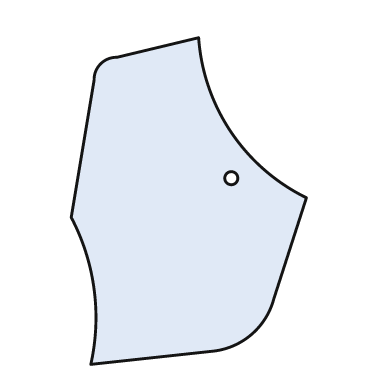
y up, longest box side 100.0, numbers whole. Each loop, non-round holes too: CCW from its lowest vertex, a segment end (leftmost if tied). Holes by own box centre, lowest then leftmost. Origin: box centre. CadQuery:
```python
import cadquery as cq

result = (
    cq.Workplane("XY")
    .moveTo(-30.0, -50.0)
    .lineTo(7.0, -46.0)
    .threePointArc((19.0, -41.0), (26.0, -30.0))
    .lineTo(36.0, 1.0)
    .threePointArc((13.0, 21.0), (3.0, 50.0))
    .lineTo(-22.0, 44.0)
    .threePointArc((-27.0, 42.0), (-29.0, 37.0))
    .lineTo(-36.0, -5.0)
    .threePointArc((-29.0, -27.0), (-30.0, -50.0))
    .close()
    .moveTo(13.0, 7.0)
    .circle(2.0)
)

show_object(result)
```